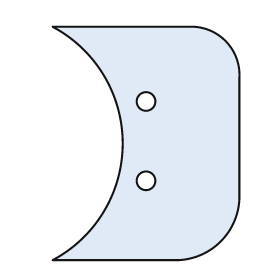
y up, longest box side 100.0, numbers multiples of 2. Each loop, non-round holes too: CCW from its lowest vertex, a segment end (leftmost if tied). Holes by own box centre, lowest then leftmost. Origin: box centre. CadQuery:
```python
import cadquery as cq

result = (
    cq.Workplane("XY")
    .moveTo(-40.0, -50.0)
    .lineTo(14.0, -50.0)
    .threePointArc((32.0, -42.0), (40.0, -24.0))
    .lineTo(40.0, 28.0)
    .threePointArc((34.0, 44.0), (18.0, 50.0))
    .lineTo(-40.0, 50.0)
    .threePointArc((-10.0, 0.0), (-40.0, -50.0))
    .close()
    .moveTo(0.0, -16.0)
    .circle(4.0)
    .moveTo(0.0, 18.0)
    .circle(4.0)
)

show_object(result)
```